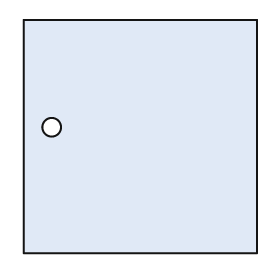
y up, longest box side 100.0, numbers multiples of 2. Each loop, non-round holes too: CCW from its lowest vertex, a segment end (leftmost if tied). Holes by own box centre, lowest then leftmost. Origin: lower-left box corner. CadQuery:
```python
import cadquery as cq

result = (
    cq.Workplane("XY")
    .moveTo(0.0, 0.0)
    .lineTo(100.0, 0.0)
    .lineTo(100.0, 100.0)
    .lineTo(0.0, 100.0)
    .close()
    .moveTo(12.0, 54.0)
    .circle(4.0)
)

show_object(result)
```